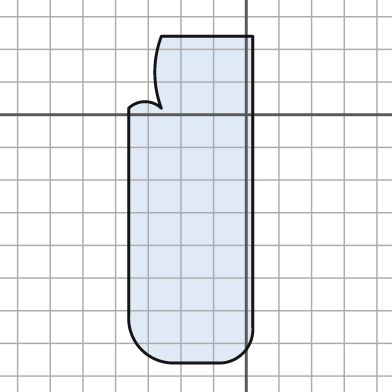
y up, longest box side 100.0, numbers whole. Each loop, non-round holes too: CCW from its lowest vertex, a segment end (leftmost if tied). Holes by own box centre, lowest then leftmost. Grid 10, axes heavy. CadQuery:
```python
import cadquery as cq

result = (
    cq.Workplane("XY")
    .moveTo(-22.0, -76.0)
    .lineTo(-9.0, -76.0)
    .threePointArc((-1.0, -73.0), (2.0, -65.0))
    .lineTo(2.0, 24.0)
    .lineTo(-26.0, 24.0)
    .threePointArc((-28.0, 13.0), (-26.0, 2.0))
    .threePointArc((-31.0, 4.0), (-36.0, 2.0))
    .lineTo(-36.0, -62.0)
    .threePointArc((-32.0, -72.0), (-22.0, -76.0))
    .close()
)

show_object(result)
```